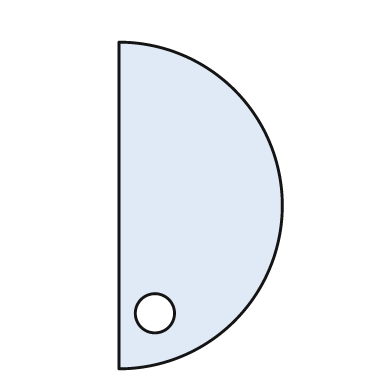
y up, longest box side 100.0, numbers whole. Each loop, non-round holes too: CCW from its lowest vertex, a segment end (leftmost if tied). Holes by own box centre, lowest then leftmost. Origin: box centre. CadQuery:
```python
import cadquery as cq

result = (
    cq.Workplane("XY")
    .moveTo(-25.0, -50.0)
    .threePointArc((25.0, 0.0), (-25.0, 50.0))
    .close()
    .moveTo(-14.0, -33.0)
    .circle(6.0)
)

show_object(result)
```